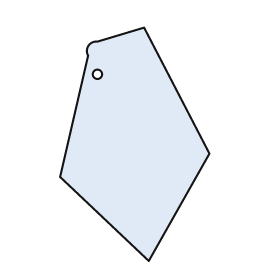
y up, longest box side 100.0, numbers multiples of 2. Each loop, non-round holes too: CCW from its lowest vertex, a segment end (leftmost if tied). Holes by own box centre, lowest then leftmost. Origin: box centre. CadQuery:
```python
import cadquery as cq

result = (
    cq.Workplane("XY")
    .moveTo(6.0, -50.0)
    .lineTo(32.0, -4.0)
    .lineTo(4.0, 50.0)
    .lineTo(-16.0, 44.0)
    .threePointArc((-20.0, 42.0), (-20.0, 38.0))
    .lineTo(-32.0, -14.0)
    .close()
    .moveTo(-16.0, 30.0)
    .circle(2.0)
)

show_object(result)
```